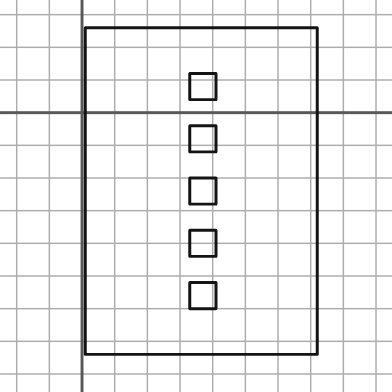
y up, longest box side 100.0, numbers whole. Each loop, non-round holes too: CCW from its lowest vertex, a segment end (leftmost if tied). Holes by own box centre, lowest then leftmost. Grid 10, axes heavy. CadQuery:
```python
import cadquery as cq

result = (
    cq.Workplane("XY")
    .moveTo(1.0, -74.0)
    .lineTo(72.0, -74.0)
    .lineTo(72.0, 26.0)
    .lineTo(1.0, 26.0)
    .close()
    .moveTo(33.0, -60.0)
    .lineTo(41.0, -60.0)
    .lineTo(41.0, -52.0)
    .lineTo(33.0, -52.0)
    .close()
    .moveTo(33.0, -44.0)
    .lineTo(41.0, -44.0)
    .lineTo(41.0, -36.0)
    .lineTo(33.0, -36.0)
    .close()
    .moveTo(33.0, -28.0)
    .lineTo(41.0, -28.0)
    .lineTo(41.0, -20.0)
    .lineTo(33.0, -20.0)
    .close()
    .moveTo(33.0, -12.0)
    .lineTo(41.0, -12.0)
    .lineTo(41.0, -4.0)
    .lineTo(33.0, -4.0)
    .close()
    .moveTo(33.0, 4.0)
    .lineTo(41.0, 4.0)
    .lineTo(41.0, 12.0)
    .lineTo(33.0, 12.0)
    .close()
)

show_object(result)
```